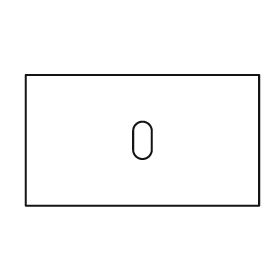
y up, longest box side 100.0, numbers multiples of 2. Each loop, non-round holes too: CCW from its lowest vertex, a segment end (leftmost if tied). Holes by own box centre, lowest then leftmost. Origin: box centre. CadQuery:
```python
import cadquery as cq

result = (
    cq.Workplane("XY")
    .moveTo(-50.0, -28.0)
    .lineTo(50.0, -28.0)
    .lineTo(50.0, 28.0)
    .lineTo(-50.0, 28.0)
    .close()
    .moveTo(-4.0, -4.0)
    .threePointArc((0.0, -8.0), (4.0, -4.0))
    .lineTo(4.0, 4.0)
    .threePointArc((0.0, 8.0), (-4.0, 4.0))
    .close()
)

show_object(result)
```